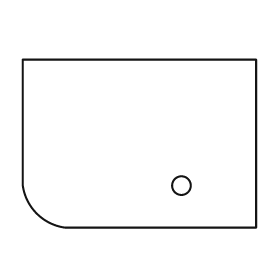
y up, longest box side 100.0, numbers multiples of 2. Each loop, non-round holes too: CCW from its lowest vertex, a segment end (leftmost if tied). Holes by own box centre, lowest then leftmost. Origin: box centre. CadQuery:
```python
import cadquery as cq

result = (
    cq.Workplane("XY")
    .moveTo(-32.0, -36.0)
    .lineTo(50.0, -36.0)
    .lineTo(50.0, 36.0)
    .lineTo(-50.0, 36.0)
    .lineTo(-50.0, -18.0)
    .threePointArc((-44.0, -30.0), (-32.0, -36.0))
    .close()
    .moveTo(18.0, -18.0)
    .circle(4.0)
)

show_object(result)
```